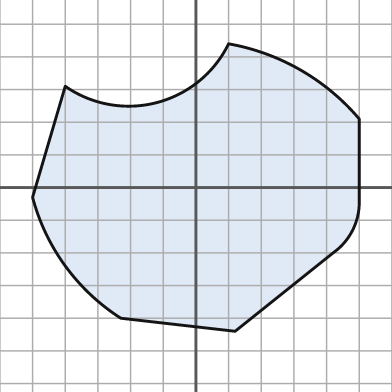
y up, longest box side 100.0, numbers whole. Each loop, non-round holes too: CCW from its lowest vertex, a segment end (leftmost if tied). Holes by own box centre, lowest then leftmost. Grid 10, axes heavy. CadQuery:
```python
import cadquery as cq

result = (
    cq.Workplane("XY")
    .moveTo(12.0, -44.0)
    .lineTo(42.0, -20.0)
    .threePointArc((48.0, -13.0), (50.0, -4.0))
    .lineTo(50.0, 21.0)
    .threePointArc((32.0, 36.0), (10.0, 44.0))
    .threePointArc((-12.0, 26.0), (-40.0, 31.0))
    .lineTo(-50.0, -3.0)
    .threePointArc((-40.0, -24.0), (-23.0, -40.0))
    .close()
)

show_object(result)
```